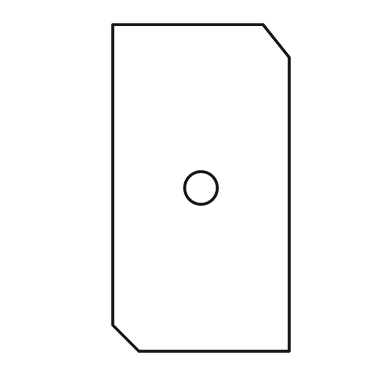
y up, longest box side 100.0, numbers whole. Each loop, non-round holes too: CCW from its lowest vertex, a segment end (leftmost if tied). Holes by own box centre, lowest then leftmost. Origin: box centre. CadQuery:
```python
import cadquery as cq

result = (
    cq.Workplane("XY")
    .moveTo(-19.0, -50.0)
    .lineTo(27.0, -50.0)
    .lineTo(27.0, 40.0)
    .lineTo(19.0, 50.0)
    .lineTo(-27.0, 50.0)
    .lineTo(-27.0, -42.0)
    .close()
    .moveTo(0.0, 0.0)
    .circle(5.0)
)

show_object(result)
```